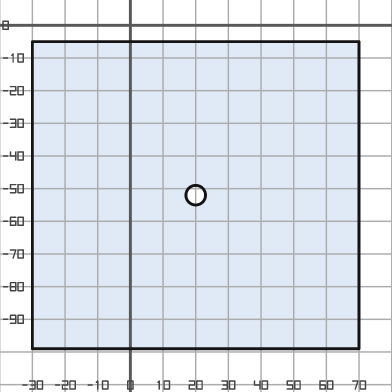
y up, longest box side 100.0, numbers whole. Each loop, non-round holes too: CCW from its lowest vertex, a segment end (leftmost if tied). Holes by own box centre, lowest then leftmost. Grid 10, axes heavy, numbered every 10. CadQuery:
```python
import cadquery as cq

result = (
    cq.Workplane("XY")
    .moveTo(-30.0, -99.0)
    .lineTo(70.0, -99.0)
    .lineTo(70.0, -5.0)
    .lineTo(-30.0, -5.0)
    .close()
    .moveTo(20.0, -52.0)
    .circle(3.0)
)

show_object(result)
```